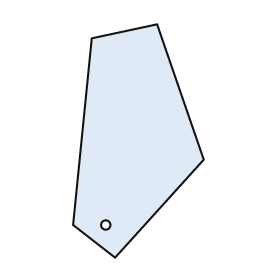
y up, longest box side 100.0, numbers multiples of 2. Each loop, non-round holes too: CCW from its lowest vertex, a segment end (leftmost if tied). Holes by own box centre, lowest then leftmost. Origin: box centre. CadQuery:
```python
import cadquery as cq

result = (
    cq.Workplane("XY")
    .moveTo(-10.0, -50.0)
    .lineTo(28.0, -8.0)
    .lineTo(8.0, 50.0)
    .lineTo(-20.0, 44.0)
    .lineTo(-28.0, -36.0)
    .close()
    .moveTo(-14.0, -36.0)
    .circle(2.0)
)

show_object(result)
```